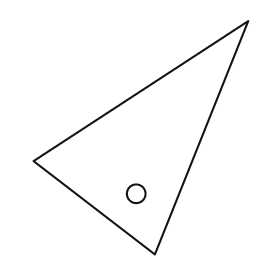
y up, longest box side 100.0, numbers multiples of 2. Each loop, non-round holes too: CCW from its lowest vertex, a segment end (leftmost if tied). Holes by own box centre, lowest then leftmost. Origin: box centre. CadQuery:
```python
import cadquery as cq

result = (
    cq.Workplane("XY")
    .moveTo(6.0, -50.0)
    .lineTo(46.0, 50.0)
    .lineTo(-46.0, -10.0)
    .close()
    .moveTo(-2.0, -24.0)
    .circle(4.0)
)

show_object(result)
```